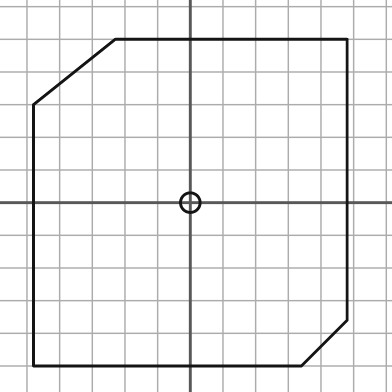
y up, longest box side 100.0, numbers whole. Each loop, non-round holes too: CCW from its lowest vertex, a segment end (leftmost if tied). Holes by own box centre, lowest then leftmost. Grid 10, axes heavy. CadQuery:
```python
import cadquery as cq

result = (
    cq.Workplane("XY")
    .moveTo(-48.0, -50.0)
    .lineTo(34.0, -50.0)
    .lineTo(48.0, -36.0)
    .lineTo(48.0, 50.0)
    .lineTo(-23.0, 50.0)
    .lineTo(-48.0, 30.0)
    .close()
    .moveTo(0.0, 0.0)
    .circle(3.0)
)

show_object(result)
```